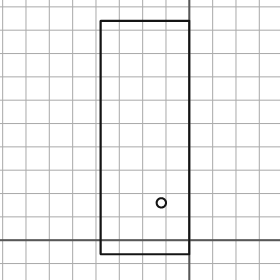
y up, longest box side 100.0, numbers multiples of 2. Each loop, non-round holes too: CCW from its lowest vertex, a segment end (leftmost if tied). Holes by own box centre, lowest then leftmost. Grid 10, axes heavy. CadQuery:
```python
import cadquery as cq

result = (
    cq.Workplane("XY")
    .moveTo(-38.0, -6.0)
    .lineTo(0.0, -6.0)
    .lineTo(0.0, 94.0)
    .lineTo(-38.0, 94.0)
    .close()
    .moveTo(-12.0, 16.0)
    .circle(2.0)
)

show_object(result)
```